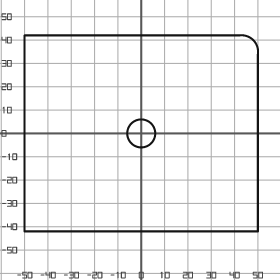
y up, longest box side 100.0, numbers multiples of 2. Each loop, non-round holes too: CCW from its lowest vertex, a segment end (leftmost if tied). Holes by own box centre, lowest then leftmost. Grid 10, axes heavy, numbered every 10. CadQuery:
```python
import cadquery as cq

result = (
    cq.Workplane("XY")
    .moveTo(-50.0, -42.0)
    .lineTo(50.0, -42.0)
    .lineTo(50.0, 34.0)
    .threePointArc((48.0, 40.0), (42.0, 42.0))
    .lineTo(-50.0, 42.0)
    .close()
    .moveTo(0.0, 0.0)
    .circle(6.0)
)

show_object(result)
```